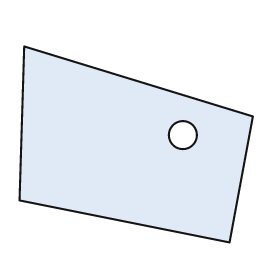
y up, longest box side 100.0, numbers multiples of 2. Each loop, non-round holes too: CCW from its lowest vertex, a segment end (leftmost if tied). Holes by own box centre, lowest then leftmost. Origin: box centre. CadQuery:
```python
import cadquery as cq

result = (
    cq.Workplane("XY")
    .moveTo(40.0, -42.0)
    .lineTo(50.0, 12.0)
    .lineTo(-48.0, 42.0)
    .lineTo(-50.0, -24.0)
    .close()
    .moveTo(20.0, 4.0)
    .circle(6.0)
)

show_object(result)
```